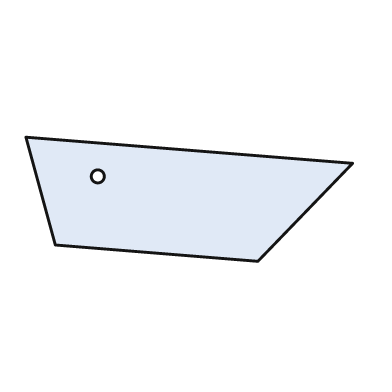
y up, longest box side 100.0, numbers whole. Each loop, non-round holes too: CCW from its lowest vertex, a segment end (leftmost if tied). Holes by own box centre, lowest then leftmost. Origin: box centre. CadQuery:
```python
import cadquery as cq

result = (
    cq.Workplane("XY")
    .moveTo(21.0, -19.0)
    .lineTo(50.0, 11.0)
    .lineTo(-50.0, 19.0)
    .lineTo(-41.0, -14.0)
    .close()
    .moveTo(-28.0, 7.0)
    .circle(2.0)
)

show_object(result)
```